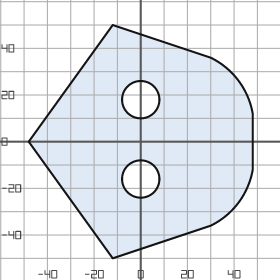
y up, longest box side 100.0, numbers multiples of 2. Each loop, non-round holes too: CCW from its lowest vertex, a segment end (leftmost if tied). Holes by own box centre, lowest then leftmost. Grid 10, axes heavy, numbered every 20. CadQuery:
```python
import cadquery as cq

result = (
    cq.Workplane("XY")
    .moveTo(-12.0, -50.0)
    .lineTo(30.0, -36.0)
    .threePointArc((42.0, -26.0), (48.0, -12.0))
    .lineTo(48.0, 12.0)
    .threePointArc((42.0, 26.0), (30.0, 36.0))
    .lineTo(-12.0, 50.0)
    .lineTo(-48.0, 0.0)
    .close()
    .moveTo(0.0, -16.0)
    .circle(8.0)
    .moveTo(0.0, 18.0)
    .circle(8.0)
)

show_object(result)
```